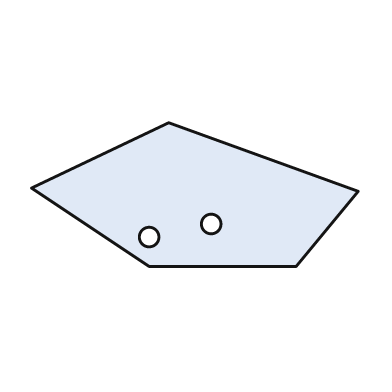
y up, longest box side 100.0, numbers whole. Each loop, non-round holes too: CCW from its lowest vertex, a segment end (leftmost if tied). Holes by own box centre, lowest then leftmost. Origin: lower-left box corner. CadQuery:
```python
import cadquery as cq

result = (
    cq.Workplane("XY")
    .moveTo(36.0, 0.0)
    .lineTo(81.0, 0.0)
    .lineTo(100.0, 23.0)
    .lineTo(42.0, 44.0)
    .lineTo(0.0, 24.0)
    .close()
    .moveTo(36.0, 9.0)
    .circle(3.0)
    .moveTo(55.0, 13.0)
    .circle(3.0)
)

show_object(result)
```